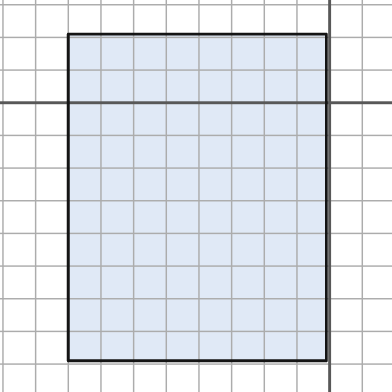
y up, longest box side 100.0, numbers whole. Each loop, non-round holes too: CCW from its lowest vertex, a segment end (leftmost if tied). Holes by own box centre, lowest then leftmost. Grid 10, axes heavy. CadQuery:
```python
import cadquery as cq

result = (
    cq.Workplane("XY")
    .moveTo(-80.0, -79.0)
    .lineTo(-1.0, -79.0)
    .lineTo(-1.0, 21.0)
    .lineTo(-80.0, 21.0)
    .close()
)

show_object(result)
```